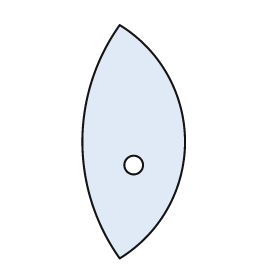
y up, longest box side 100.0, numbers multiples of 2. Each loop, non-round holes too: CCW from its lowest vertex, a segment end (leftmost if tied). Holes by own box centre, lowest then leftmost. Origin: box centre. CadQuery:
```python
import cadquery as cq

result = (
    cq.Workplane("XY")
    .moveTo(-6.0, -50.0)
    .threePointArc((22.0, 0.0), (-6.0, 50.0))
    .threePointArc((-22.0, 0.0), (-6.0, -50.0))
    .close()
    .moveTo(0.0, -10.0)
    .circle(4.0)
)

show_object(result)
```